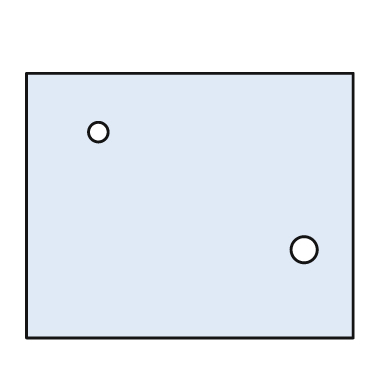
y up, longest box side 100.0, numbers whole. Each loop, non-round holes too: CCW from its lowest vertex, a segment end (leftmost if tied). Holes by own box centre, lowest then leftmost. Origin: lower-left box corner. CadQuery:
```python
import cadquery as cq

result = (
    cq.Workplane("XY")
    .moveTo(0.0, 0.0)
    .lineTo(100.0, 0.0)
    .lineTo(100.0, 81.0)
    .lineTo(0.0, 81.0)
    .close()
    .moveTo(85.0, 27.0)
    .circle(4.0)
    .moveTo(22.0, 63.0)
    .circle(3.0)
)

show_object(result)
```